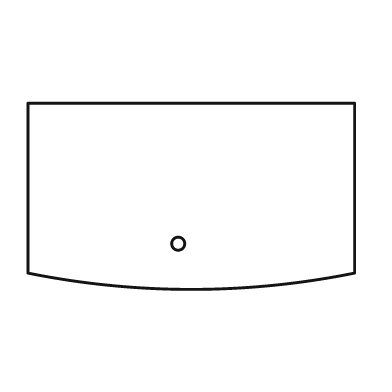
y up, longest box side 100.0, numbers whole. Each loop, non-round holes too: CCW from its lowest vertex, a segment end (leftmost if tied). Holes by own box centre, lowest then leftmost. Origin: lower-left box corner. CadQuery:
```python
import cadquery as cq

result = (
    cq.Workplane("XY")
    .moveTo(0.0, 5.0)
    .threePointArc((50.0, 0.0), (100.0, 5.0))
    .lineTo(100.0, 57.0)
    .lineTo(0.0, 57.0)
    .close()
    .moveTo(46.0, 14.0)
    .circle(2.0)
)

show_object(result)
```